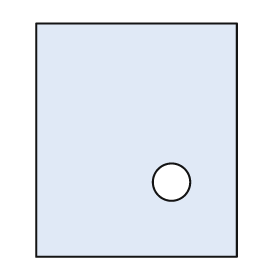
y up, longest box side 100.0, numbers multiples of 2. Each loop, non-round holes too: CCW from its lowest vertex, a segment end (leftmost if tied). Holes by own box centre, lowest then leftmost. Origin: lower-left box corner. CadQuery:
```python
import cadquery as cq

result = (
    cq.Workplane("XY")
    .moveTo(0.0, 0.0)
    .lineTo(86.0, 0.0)
    .lineTo(86.0, 100.0)
    .lineTo(0.0, 100.0)
    .close()
    .moveTo(58.0, 32.0)
    .circle(8.0)
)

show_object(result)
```